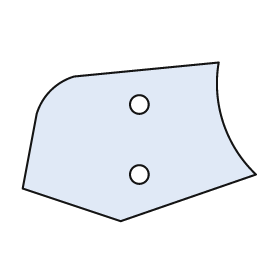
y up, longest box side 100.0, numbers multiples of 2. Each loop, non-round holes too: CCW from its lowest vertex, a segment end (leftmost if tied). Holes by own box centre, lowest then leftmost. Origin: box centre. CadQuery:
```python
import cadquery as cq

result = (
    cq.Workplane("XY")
    .moveTo(-8.0, -34.0)
    .lineTo(50.0, -14.0)
    .threePointArc((36.0, 8.0), (34.0, 34.0))
    .lineTo(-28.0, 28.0)
    .threePointArc((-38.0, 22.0), (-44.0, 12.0))
    .lineTo(-50.0, -20.0)
    .close()
    .moveTo(0.0, -14.0)
    .circle(4.0)
    .moveTo(0.0, 16.0)
    .circle(4.0)
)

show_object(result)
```